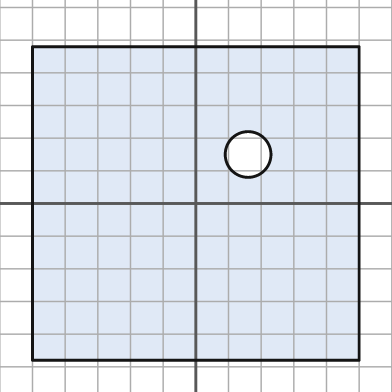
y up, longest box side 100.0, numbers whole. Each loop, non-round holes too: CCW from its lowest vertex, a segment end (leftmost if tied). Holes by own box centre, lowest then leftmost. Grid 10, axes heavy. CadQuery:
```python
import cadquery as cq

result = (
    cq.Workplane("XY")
    .moveTo(-50.0, -48.0)
    .lineTo(50.0, -48.0)
    .lineTo(50.0, 48.0)
    .lineTo(-50.0, 48.0)
    .close()
    .moveTo(16.0, 15.0)
    .circle(7.0)
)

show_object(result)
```